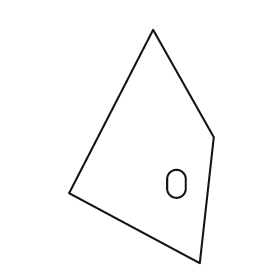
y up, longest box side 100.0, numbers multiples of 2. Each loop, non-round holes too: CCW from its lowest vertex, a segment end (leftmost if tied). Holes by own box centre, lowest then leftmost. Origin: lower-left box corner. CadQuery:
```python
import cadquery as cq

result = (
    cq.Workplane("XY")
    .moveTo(56.0, 0.0)
    .lineTo(62.0, 54.0)
    .lineTo(36.0, 100.0)
    .lineTo(0.0, 30.0)
    .close()
    .moveTo(42.0, 32.0)
    .threePointArc((46.0, 28.0), (50.0, 32.0))
    .lineTo(50.0, 36.0)
    .threePointArc((46.0, 40.0), (42.0, 36.0))
    .close()
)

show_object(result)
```